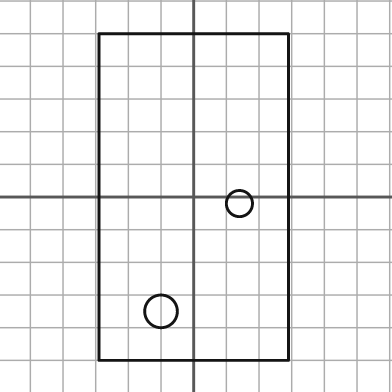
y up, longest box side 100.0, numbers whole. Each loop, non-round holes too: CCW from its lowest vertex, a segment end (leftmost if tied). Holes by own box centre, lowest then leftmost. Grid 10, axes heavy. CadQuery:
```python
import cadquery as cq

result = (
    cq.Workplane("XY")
    .moveTo(-29.0, -50.0)
    .lineTo(29.0, -50.0)
    .lineTo(29.0, 50.0)
    .lineTo(-29.0, 50.0)
    .close()
    .moveTo(-10.0, -35.0)
    .circle(5.0)
    .moveTo(14.0, -2.0)
    .circle(4.0)
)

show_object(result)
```